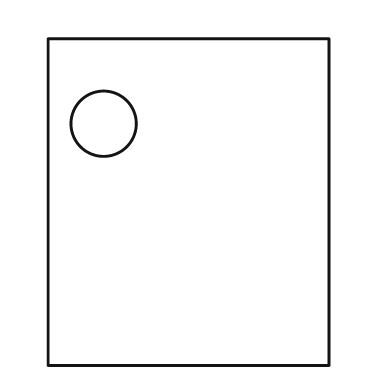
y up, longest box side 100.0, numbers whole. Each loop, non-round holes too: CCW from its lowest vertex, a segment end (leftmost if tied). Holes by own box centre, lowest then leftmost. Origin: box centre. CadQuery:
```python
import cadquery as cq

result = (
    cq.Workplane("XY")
    .moveTo(-43.0, -50.0)
    .lineTo(43.0, -50.0)
    .lineTo(43.0, 50.0)
    .lineTo(-43.0, 50.0)
    .close()
    .moveTo(-26.0, 24.0)
    .circle(10.0)
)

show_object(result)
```